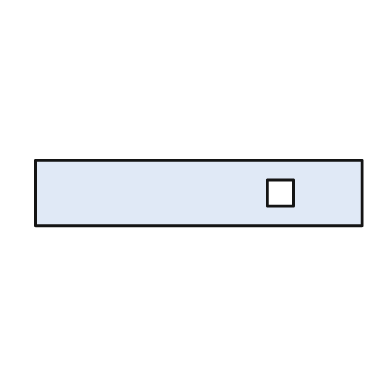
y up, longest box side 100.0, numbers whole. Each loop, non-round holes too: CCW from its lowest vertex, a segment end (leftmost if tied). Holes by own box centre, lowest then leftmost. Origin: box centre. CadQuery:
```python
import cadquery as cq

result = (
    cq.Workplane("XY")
    .moveTo(-50.0, -10.0)
    .lineTo(50.0, -10.0)
    .lineTo(50.0, 10.0)
    .lineTo(-50.0, 10.0)
    .close()
    .moveTo(21.0, -4.0)
    .lineTo(29.0, -4.0)
    .lineTo(29.0, 4.0)
    .lineTo(21.0, 4.0)
    .close()
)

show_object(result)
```